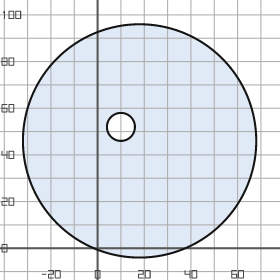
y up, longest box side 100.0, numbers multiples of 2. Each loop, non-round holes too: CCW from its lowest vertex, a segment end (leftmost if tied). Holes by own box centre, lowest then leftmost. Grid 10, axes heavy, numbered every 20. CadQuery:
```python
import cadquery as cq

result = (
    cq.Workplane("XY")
    .moveTo(18.0, 46.0)
    .circle(50.0)
    .moveTo(10.0, 52.0)
    .circle(6.0)
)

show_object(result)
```